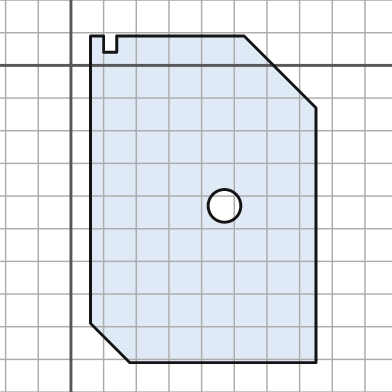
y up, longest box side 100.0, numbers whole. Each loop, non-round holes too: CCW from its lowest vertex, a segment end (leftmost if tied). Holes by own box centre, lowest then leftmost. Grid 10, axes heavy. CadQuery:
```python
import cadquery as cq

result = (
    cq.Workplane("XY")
    .moveTo(18.0, -91.0)
    .lineTo(75.0, -91.0)
    .lineTo(75.0, -13.0)
    .lineTo(53.0, 9.0)
    .lineTo(14.0, 9.0)
    .lineTo(14.0, 4.0)
    .lineTo(10.0, 4.0)
    .lineTo(10.0, 9.0)
    .lineTo(6.0, 9.0)
    .lineTo(6.0, -79.0)
    .close()
    .moveTo(47.0, -43.0)
    .circle(5.0)
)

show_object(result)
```